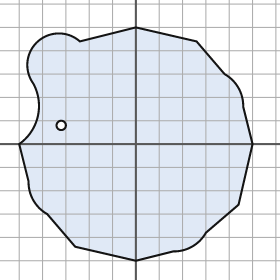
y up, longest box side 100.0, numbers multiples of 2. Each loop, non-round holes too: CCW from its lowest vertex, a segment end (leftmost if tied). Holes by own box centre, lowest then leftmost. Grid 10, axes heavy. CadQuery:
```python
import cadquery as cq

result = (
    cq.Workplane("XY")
    .moveTo(0.0, -50.0)
    .lineTo(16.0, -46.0)
    .threePointArc((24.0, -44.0), (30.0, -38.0))
    .lineTo(44.0, -26.0)
    .lineTo(50.0, 0.0)
    .lineTo(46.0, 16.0)
    .threePointArc((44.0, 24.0), (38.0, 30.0))
    .lineTo(26.0, 44.0)
    .lineTo(0.0, 50.0)
    .lineTo(-24.0, 44.0)
    .threePointArc((-42.0, 44.0), (-44.0, 26.0))
    .threePointArc((-42.0, 12.0), (-50.0, 0.0))
    .lineTo(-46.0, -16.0)
    .threePointArc((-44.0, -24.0), (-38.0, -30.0))
    .lineTo(-26.0, -44.0)
    .close()
    .moveTo(-32.0, 8.0)
    .circle(2.0)
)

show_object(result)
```